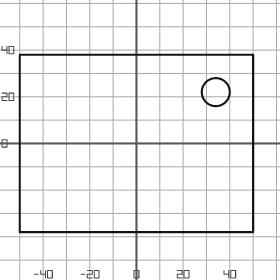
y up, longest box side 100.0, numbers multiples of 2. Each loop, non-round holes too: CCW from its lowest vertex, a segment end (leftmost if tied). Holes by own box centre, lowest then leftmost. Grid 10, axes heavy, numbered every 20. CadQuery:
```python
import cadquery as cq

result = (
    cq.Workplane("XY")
    .moveTo(-50.0, -38.0)
    .lineTo(50.0, -38.0)
    .lineTo(50.0, 38.0)
    .lineTo(-50.0, 38.0)
    .close()
    .moveTo(34.0, 22.0)
    .circle(6.0)
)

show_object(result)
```